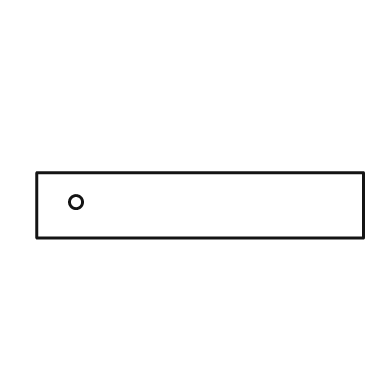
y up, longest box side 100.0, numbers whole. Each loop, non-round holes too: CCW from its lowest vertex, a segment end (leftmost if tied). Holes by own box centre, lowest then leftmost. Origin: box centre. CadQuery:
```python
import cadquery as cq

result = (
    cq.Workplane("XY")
    .moveTo(-50.0, -10.0)
    .lineTo(50.0, -10.0)
    .lineTo(50.0, 10.0)
    .lineTo(-50.0, 10.0)
    .close()
    .moveTo(-38.0, 1.0)
    .circle(2.0)
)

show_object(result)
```